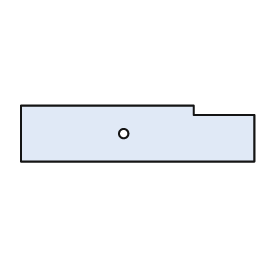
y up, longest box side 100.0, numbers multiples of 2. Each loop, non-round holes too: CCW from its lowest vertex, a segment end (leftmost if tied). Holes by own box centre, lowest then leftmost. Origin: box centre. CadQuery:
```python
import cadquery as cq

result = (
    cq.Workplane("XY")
    .moveTo(-50.0, -12.0)
    .lineTo(50.0, -12.0)
    .lineTo(50.0, 8.0)
    .lineTo(24.0, 8.0)
    .lineTo(24.0, 12.0)
    .lineTo(-50.0, 12.0)
    .close()
    .moveTo(-6.0, 0.0)
    .circle(2.0)
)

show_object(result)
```